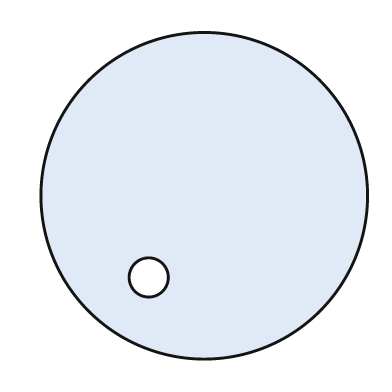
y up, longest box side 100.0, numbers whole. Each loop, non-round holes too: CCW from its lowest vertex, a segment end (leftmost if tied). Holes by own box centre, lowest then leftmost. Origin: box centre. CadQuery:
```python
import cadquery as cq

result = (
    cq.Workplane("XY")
    .moveTo(0.0, 0.0)
    .circle(50.0)
    .moveTo(-17.0, -25.0)
    .circle(6.0)
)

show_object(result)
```